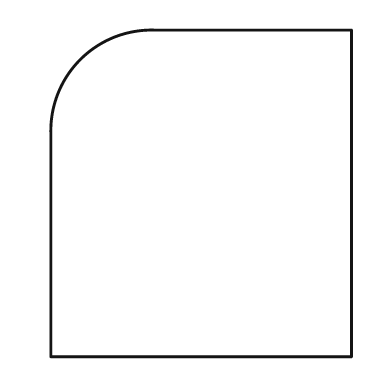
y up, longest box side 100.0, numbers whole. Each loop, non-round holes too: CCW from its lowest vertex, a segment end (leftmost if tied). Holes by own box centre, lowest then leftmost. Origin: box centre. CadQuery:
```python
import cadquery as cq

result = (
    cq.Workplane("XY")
    .moveTo(-46.0, -50.0)
    .lineTo(46.0, -50.0)
    .lineTo(46.0, 50.0)
    .lineTo(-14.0, 50.0)
    .threePointArc((-37.0, 41.0), (-46.0, 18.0))
    .close()
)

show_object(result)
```